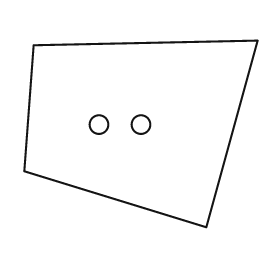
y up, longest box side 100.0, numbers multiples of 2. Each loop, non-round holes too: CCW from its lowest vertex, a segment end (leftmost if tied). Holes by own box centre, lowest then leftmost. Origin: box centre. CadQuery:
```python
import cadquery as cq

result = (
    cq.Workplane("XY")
    .moveTo(28.0, -40.0)
    .lineTo(50.0, 40.0)
    .lineTo(-46.0, 38.0)
    .lineTo(-50.0, -16.0)
    .close()
    .moveTo(-18.0, 4.0)
    .circle(4.0)
    .moveTo(0.0, 4.0)
    .circle(4.0)
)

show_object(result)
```